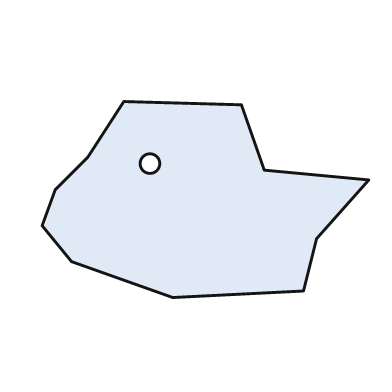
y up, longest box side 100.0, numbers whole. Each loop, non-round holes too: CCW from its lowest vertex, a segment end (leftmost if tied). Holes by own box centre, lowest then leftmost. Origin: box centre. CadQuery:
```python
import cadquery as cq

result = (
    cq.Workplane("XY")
    .moveTo(-10.0, -30.0)
    .lineTo(30.0, -28.0)
    .lineTo(34.0, -12.0)
    .lineTo(50.0, 6.0)
    .lineTo(18.0, 9.0)
    .lineTo(11.0, 29.0)
    .lineTo(-25.0, 30.0)
    .lineTo(-36.0, 13.0)
    .lineTo(-46.0, 3.0)
    .lineTo(-50.0, -8.0)
    .lineTo(-41.0, -19.0)
    .close()
    .moveTo(-17.0, 11.0)
    .circle(3.0)
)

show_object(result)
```